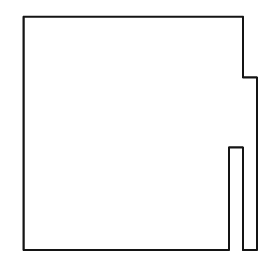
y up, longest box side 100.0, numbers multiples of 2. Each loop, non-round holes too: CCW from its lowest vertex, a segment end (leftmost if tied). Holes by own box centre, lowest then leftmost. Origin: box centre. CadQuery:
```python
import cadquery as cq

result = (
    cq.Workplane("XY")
    .moveTo(-50.0, -50.0)
    .lineTo(38.0, -50.0)
    .lineTo(38.0, -6.0)
    .lineTo(44.0, -6.0)
    .lineTo(44.0, -50.0)
    .lineTo(50.0, -50.0)
    .lineTo(50.0, 24.0)
    .lineTo(44.0, 24.0)
    .lineTo(44.0, 50.0)
    .lineTo(-50.0, 50.0)
    .close()
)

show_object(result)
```